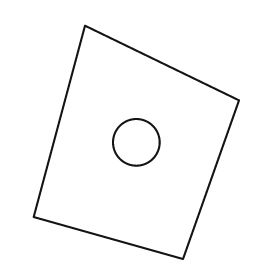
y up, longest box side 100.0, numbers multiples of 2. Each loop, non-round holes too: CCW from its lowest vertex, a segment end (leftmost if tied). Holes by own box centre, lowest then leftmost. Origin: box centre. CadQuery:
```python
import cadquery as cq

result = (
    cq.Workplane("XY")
    .moveTo(20.0, -50.0)
    .lineTo(44.0, 18.0)
    .lineTo(-22.0, 50.0)
    .lineTo(-44.0, -32.0)
    .close()
    .moveTo(0.0, 0.0)
    .circle(10.0)
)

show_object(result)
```